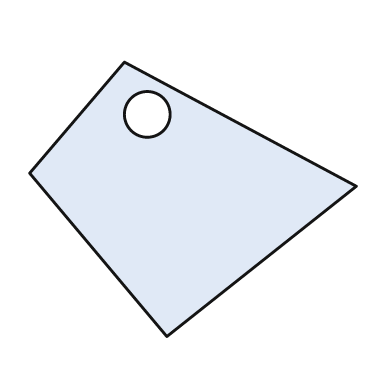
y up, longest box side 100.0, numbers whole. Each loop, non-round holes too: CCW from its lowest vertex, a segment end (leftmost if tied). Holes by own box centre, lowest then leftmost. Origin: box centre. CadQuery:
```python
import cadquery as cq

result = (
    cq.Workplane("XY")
    .moveTo(-8.0, -42.0)
    .lineTo(50.0, 4.0)
    .lineTo(-21.0, 42.0)
    .lineTo(-50.0, 8.0)
    .close()
    .moveTo(-14.0, 26.0)
    .circle(7.0)
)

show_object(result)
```